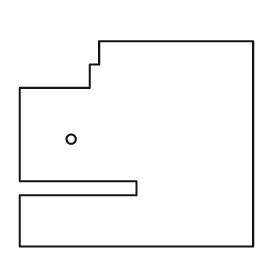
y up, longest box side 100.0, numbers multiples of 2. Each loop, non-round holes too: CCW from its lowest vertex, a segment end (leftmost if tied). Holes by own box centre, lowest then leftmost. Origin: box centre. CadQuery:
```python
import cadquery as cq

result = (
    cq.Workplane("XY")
    .moveTo(-50.0, -44.0)
    .lineTo(50.0, -44.0)
    .lineTo(50.0, 44.0)
    .lineTo(-16.0, 44.0)
    .lineTo(-16.0, 34.0)
    .lineTo(-20.0, 34.0)
    .lineTo(-20.0, 24.0)
    .lineTo(-50.0, 24.0)
    .lineTo(-50.0, -16.0)
    .lineTo(0.0, -16.0)
    .lineTo(0.0, -22.0)
    .lineTo(-50.0, -22.0)
    .close()
    .moveTo(-28.0, 2.0)
    .circle(2.0)
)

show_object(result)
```